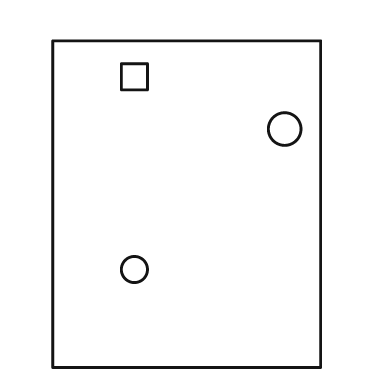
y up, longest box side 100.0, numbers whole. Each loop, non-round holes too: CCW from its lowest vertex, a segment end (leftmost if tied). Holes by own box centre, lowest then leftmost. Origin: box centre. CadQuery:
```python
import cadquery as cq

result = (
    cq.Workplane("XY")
    .moveTo(-41.0, -50.0)
    .lineTo(41.0, -50.0)
    .lineTo(41.0, 50.0)
    .lineTo(-41.0, 50.0)
    .close()
    .moveTo(-16.0, -20.0)
    .circle(4.0)
    .moveTo(30.0, 23.0)
    .circle(5.0)
    .moveTo(-20.0, 35.0)
    .lineTo(-12.0, 35.0)
    .lineTo(-12.0, 43.0)
    .lineTo(-20.0, 43.0)
    .close()
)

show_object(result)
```